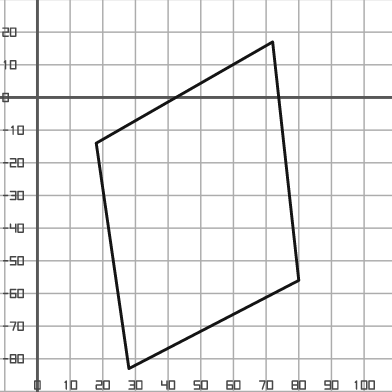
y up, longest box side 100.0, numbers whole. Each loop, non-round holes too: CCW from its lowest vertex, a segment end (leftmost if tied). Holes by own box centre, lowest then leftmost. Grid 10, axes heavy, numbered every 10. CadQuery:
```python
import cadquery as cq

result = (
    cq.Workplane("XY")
    .moveTo(28.0, -83.0)
    .lineTo(80.0, -56.0)
    .lineTo(72.0, 17.0)
    .lineTo(18.0, -14.0)
    .close()
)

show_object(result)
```